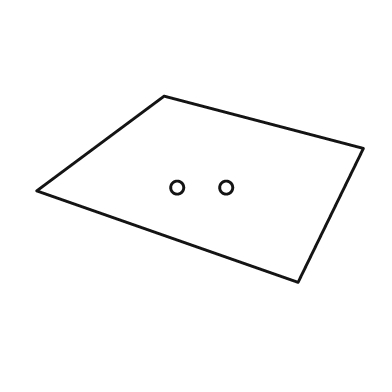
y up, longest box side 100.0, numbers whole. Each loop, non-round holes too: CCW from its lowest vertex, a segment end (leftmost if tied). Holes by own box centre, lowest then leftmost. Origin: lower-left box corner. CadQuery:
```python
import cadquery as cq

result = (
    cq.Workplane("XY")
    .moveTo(80.0, 0.0)
    .lineTo(100.0, 41.0)
    .lineTo(39.0, 57.0)
    .lineTo(0.0, 28.0)
    .close()
    .moveTo(43.0, 29.0)
    .circle(2.0)
    .moveTo(58.0, 29.0)
    .circle(2.0)
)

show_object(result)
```